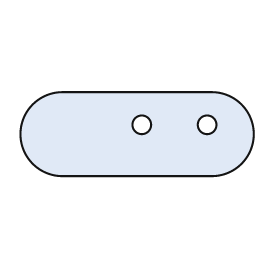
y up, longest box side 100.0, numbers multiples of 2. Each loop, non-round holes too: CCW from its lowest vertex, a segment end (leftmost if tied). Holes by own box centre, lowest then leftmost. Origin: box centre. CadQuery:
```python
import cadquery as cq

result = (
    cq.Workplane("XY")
    .moveTo(-32.0, -18.0)
    .lineTo(32.0, -18.0)
    .threePointArc((50.0, 0.0), (32.0, 18.0))
    .lineTo(-32.0, 18.0)
    .threePointArc((-50.0, 0.0), (-32.0, -18.0))
    .close()
    .moveTo(2.0, 4.0)
    .circle(4.0)
    .moveTo(30.0, 4.0)
    .circle(4.0)
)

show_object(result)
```